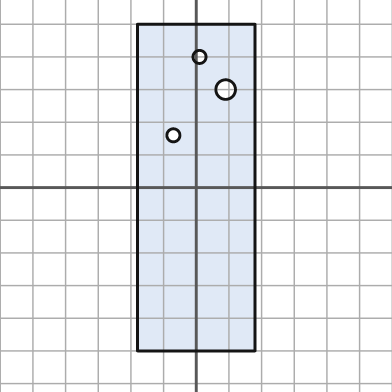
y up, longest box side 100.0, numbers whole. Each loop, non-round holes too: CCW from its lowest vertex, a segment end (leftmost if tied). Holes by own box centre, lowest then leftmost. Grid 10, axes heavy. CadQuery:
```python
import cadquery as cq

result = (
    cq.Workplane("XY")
    .moveTo(-18.0, -50.0)
    .lineTo(18.0, -50.0)
    .lineTo(18.0, 50.0)
    .lineTo(-18.0, 50.0)
    .close()
    .moveTo(-7.0, 16.0)
    .circle(2.0)
    .moveTo(9.0, 30.0)
    .circle(3.0)
    .moveTo(1.0, 40.0)
    .circle(2.0)
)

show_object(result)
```